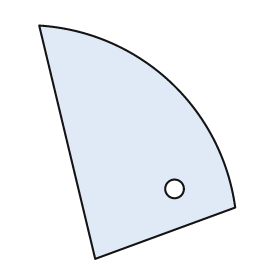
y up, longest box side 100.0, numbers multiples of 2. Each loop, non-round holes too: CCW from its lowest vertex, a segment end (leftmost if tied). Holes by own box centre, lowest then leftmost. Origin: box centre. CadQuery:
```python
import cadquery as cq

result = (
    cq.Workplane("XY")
    .moveTo(-18.0, -50.0)
    .lineTo(42.0, -28.0)
    .threePointArc((14.0, 26.0), (-42.0, 50.0))
    .close()
    .moveTo(16.0, -20.0)
    .circle(4.0)
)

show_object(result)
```